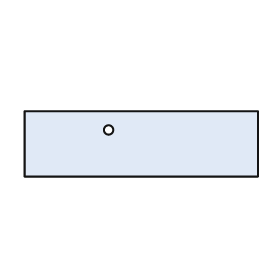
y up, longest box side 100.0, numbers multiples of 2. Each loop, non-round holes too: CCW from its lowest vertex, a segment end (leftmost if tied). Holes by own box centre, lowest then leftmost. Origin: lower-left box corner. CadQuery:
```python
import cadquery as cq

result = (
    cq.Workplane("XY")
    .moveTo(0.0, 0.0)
    .lineTo(100.0, 0.0)
    .lineTo(100.0, 28.0)
    .lineTo(0.0, 28.0)
    .close()
    .moveTo(36.0, 20.0)
    .circle(2.0)
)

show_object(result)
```